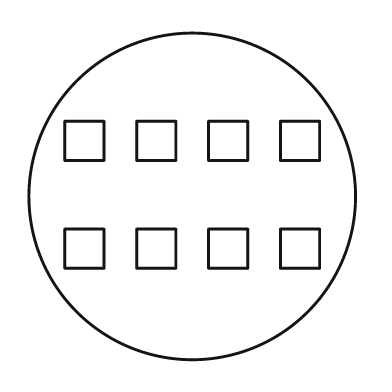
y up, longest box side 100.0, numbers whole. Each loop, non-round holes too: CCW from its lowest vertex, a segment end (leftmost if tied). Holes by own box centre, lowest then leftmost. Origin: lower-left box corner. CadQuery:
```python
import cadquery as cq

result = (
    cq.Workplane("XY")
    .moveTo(50.0, 50.0)
    .circle(50.0)
    .moveTo(11.0, 28.0)
    .lineTo(23.0, 28.0)
    .lineTo(23.0, 40.0)
    .lineTo(11.0, 40.0)
    .close()
    .moveTo(33.0, 28.0)
    .lineTo(45.0, 28.0)
    .lineTo(45.0, 40.0)
    .lineTo(33.0, 40.0)
    .close()
    .moveTo(55.0, 28.0)
    .lineTo(67.0, 28.0)
    .lineTo(67.0, 40.0)
    .lineTo(55.0, 40.0)
    .close()
    .moveTo(77.0, 28.0)
    .lineTo(89.0, 28.0)
    .lineTo(89.0, 40.0)
    .lineTo(77.0, 40.0)
    .close()
    .moveTo(11.0, 61.0)
    .lineTo(23.0, 61.0)
    .lineTo(23.0, 73.0)
    .lineTo(11.0, 73.0)
    .close()
    .moveTo(33.0, 61.0)
    .lineTo(45.0, 61.0)
    .lineTo(45.0, 73.0)
    .lineTo(33.0, 73.0)
    .close()
    .moveTo(55.0, 61.0)
    .lineTo(67.0, 61.0)
    .lineTo(67.0, 73.0)
    .lineTo(55.0, 73.0)
    .close()
    .moveTo(77.0, 61.0)
    .lineTo(89.0, 61.0)
    .lineTo(89.0, 73.0)
    .lineTo(77.0, 73.0)
    .close()
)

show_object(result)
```